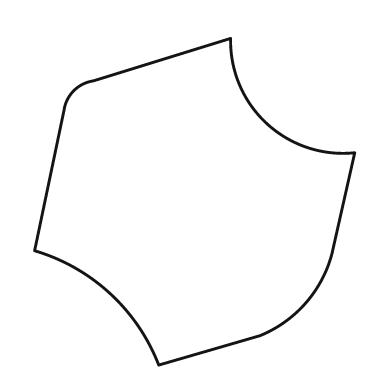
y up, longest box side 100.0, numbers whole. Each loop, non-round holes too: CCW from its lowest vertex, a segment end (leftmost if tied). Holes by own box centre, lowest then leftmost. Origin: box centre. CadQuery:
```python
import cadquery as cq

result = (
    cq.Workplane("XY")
    .moveTo(-11.0, -50.0)
    .lineTo(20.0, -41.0)
    .threePointArc((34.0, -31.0), (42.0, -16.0))
    .lineTo(49.0, 15.0)
    .threePointArc((22.0, 24.0), (11.0, 50.0))
    .lineTo(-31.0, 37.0)
    .threePointArc((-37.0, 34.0), (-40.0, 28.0))
    .lineTo(-49.0, -15.0)
    .threePointArc((-26.0, -28.0), (-11.0, -50.0))
    .close()
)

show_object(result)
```